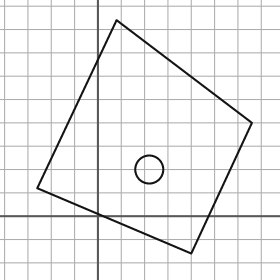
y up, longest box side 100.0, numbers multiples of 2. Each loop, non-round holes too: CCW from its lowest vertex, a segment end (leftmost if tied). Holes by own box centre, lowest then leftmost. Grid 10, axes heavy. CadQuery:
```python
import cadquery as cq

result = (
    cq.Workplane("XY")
    .moveTo(40.0, -16.0)
    .lineTo(66.0, 40.0)
    .lineTo(8.0, 84.0)
    .lineTo(-26.0, 12.0)
    .close()
    .moveTo(22.0, 20.0)
    .circle(6.0)
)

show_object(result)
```